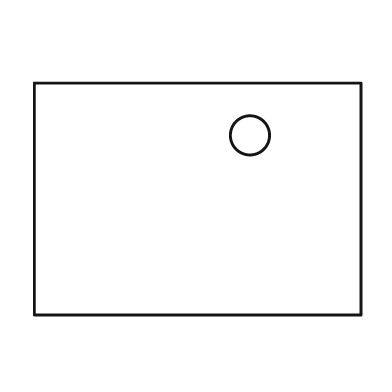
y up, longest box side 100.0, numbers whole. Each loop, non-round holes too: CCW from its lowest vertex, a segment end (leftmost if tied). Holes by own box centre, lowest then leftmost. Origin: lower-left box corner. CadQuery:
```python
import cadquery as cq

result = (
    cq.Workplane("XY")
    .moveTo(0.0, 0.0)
    .lineTo(100.0, 0.0)
    .lineTo(100.0, 71.0)
    .lineTo(0.0, 71.0)
    .close()
    .moveTo(66.0, 55.0)
    .circle(6.0)
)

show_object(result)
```